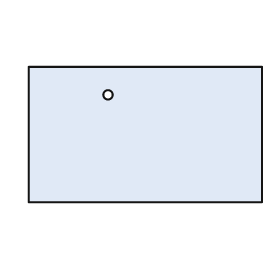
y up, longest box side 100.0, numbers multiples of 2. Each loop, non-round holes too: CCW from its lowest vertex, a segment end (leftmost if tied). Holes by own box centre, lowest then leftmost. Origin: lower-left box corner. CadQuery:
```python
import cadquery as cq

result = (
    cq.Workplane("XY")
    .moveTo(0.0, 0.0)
    .lineTo(100.0, 0.0)
    .lineTo(100.0, 58.0)
    .lineTo(0.0, 58.0)
    .close()
    .moveTo(34.0, 46.0)
    .circle(2.0)
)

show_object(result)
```